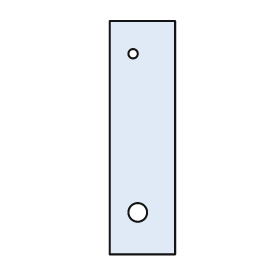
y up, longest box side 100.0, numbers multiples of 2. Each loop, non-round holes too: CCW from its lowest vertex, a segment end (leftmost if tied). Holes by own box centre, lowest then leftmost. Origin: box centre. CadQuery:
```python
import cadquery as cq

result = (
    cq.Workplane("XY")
    .moveTo(-14.0, -50.0)
    .lineTo(14.0, -50.0)
    .lineTo(14.0, 50.0)
    .lineTo(-14.0, 50.0)
    .close()
    .moveTo(-2.0, -32.0)
    .circle(4.0)
    .moveTo(-4.0, 36.0)
    .circle(2.0)
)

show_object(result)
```